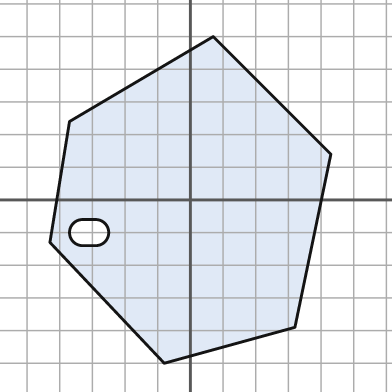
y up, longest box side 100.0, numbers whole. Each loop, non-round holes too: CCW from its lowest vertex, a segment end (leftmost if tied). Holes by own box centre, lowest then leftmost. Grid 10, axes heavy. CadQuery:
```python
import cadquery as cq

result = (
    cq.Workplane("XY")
    .moveTo(-8.0, -50.0)
    .lineTo(32.0, -39.0)
    .lineTo(43.0, 14.0)
    .lineTo(7.0, 50.0)
    .lineTo(-37.0, 24.0)
    .lineTo(-43.0, -13.0)
    .close()
    .moveTo(-33.0, -14.0)
    .lineTo(-29.0, -14.0)
    .threePointArc((-25.0, -10.0), (-29.0, -6.0))
    .lineTo(-33.0, -6.0)
    .threePointArc((-37.0, -10.0), (-33.0, -14.0))
    .close()
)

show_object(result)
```